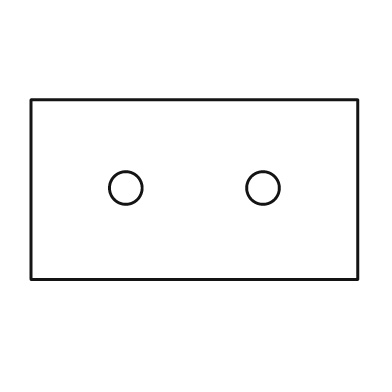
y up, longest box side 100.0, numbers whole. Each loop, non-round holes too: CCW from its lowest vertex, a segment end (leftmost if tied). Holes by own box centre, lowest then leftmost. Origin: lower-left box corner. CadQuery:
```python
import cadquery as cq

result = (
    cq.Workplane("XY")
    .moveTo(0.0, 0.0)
    .lineTo(100.0, 0.0)
    .lineTo(100.0, 55.0)
    .lineTo(0.0, 55.0)
    .close()
    .moveTo(29.0, 28.0)
    .circle(5.0)
    .moveTo(71.0, 28.0)
    .circle(5.0)
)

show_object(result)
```